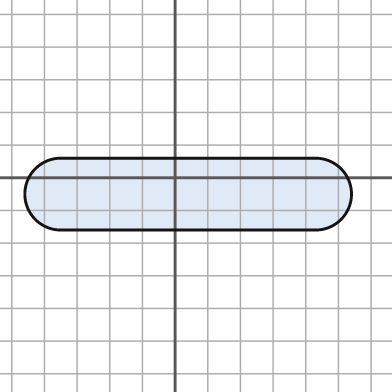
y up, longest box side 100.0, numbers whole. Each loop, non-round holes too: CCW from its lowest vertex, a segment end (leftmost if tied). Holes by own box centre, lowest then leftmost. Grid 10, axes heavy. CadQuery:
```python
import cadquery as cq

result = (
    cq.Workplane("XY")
    .moveTo(-35.0, -16.0)
    .lineTo(43.0, -16.0)
    .threePointArc((54.0, -5.0), (43.0, 6.0))
    .lineTo(-35.0, 6.0)
    .threePointArc((-46.0, -5.0), (-35.0, -16.0))
    .close()
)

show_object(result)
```